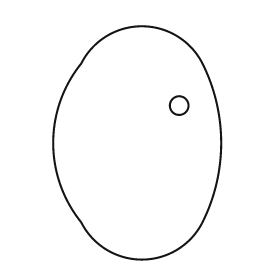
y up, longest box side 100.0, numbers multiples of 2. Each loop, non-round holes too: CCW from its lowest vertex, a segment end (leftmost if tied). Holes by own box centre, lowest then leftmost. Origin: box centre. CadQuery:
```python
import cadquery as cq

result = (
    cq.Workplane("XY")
    .moveTo(-24.0, -34.0)
    .threePointArc((2.0, -50.0), (28.0, -34.0))
    .threePointArc((36.0, 0.0), (28.0, 34.0))
    .threePointArc((2.0, 50.0), (-24.0, 34.0))
    .threePointArc((-36.0, 0.0), (-24.0, -34.0))
    .close()
    .moveTo(18.0, 16.0)
    .circle(4.0)
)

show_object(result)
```